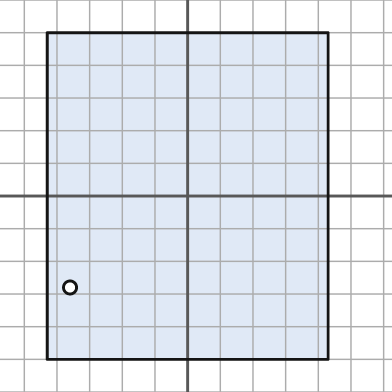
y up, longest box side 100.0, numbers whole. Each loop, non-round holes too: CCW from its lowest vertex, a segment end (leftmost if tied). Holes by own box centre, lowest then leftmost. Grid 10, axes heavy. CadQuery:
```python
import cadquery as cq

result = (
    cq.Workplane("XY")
    .moveTo(-43.0, -50.0)
    .lineTo(43.0, -50.0)
    .lineTo(43.0, 50.0)
    .lineTo(-43.0, 50.0)
    .close()
    .moveTo(-36.0, -28.0)
    .circle(2.0)
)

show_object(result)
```